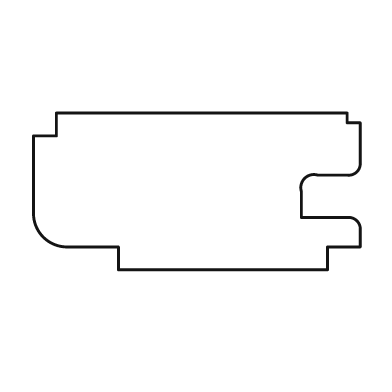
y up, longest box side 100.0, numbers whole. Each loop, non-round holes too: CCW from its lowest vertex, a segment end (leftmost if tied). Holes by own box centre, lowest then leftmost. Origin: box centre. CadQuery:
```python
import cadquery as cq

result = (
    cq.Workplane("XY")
    .moveTo(-24.0, -24.0)
    .lineTo(40.0, -24.0)
    .lineTo(40.0, -17.0)
    .lineTo(50.0, -17.0)
    .lineTo(50.0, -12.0)
    .threePointArc((49.0, -9.0), (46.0, -8.0))
    .lineTo(32.0, -8.0)
    .lineTo(32.0, 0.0)
    .threePointArc((33.0, 4.0), (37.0, 5.0))
    .lineTo(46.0, 5.0)
    .threePointArc((49.0, 6.0), (50.0, 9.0))
    .lineTo(50.0, 21.0)
    .lineTo(46.0, 21.0)
    .lineTo(46.0, 24.0)
    .lineTo(-43.0, 24.0)
    .lineTo(-43.0, 17.0)
    .lineTo(-50.0, 17.0)
    .lineTo(-50.0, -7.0)
    .threePointArc((-47.0, -14.0), (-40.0, -17.0))
    .lineTo(-24.0, -17.0)
    .close()
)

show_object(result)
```